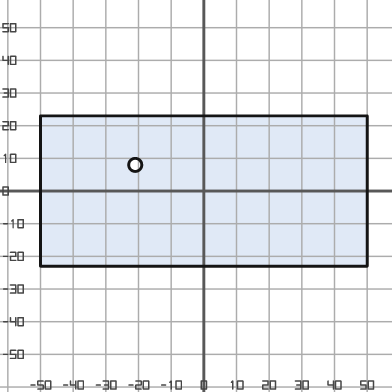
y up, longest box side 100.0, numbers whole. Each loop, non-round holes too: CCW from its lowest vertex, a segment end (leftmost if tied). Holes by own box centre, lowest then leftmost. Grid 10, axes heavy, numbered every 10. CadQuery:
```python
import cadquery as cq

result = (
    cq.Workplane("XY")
    .moveTo(-50.0, -23.0)
    .lineTo(50.0, -23.0)
    .lineTo(50.0, 23.0)
    .lineTo(-50.0, 23.0)
    .close()
    .moveTo(-21.0, 8.0)
    .circle(2.0)
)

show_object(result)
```